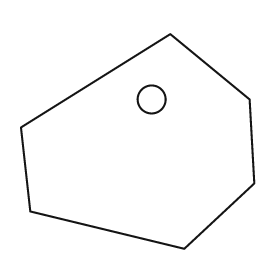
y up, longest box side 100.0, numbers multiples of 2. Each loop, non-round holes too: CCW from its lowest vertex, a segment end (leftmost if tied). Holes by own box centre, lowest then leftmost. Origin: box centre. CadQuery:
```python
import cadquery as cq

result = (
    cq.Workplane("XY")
    .moveTo(20.0, -46.0)
    .lineTo(50.0, -18.0)
    .lineTo(48.0, 18.0)
    .lineTo(14.0, 46.0)
    .lineTo(-50.0, 6.0)
    .lineTo(-46.0, -30.0)
    .close()
    .moveTo(6.0, 18.0)
    .circle(6.0)
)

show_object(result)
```